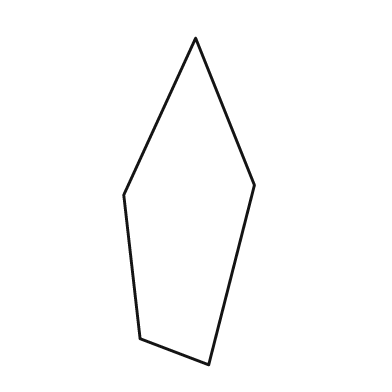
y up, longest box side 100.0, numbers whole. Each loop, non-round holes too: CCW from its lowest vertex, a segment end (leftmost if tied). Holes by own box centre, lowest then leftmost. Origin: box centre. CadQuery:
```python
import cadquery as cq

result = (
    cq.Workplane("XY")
    .moveTo(6.0, -50.0)
    .lineTo(20.0, 5.0)
    .lineTo(2.0, 50.0)
    .lineTo(-20.0, 2.0)
    .lineTo(-15.0, -42.0)
    .close()
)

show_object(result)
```